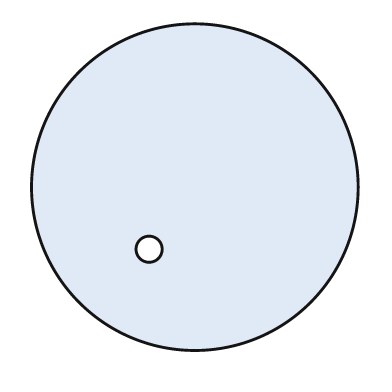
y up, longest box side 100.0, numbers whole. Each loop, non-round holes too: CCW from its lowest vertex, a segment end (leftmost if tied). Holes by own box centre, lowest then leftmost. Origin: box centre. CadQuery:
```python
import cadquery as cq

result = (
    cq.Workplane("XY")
    .moveTo(0.0, 0.0)
    .circle(50.0)
    .moveTo(-14.0, -19.0)
    .circle(4.0)
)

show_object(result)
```